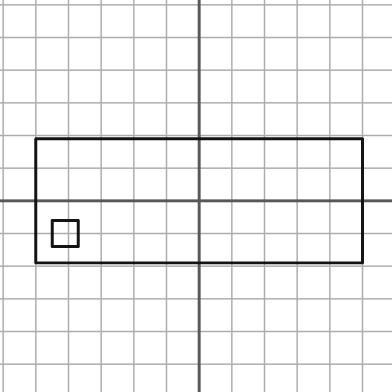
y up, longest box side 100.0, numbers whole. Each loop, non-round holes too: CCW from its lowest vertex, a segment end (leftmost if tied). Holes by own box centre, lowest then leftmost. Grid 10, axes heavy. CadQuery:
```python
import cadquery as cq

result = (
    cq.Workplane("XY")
    .moveTo(-50.0, -19.0)
    .lineTo(50.0, -19.0)
    .lineTo(50.0, 19.0)
    .lineTo(-50.0, 19.0)
    .close()
    .moveTo(-45.0, -14.0)
    .lineTo(-37.0, -14.0)
    .lineTo(-37.0, -6.0)
    .lineTo(-45.0, -6.0)
    .close()
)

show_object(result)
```